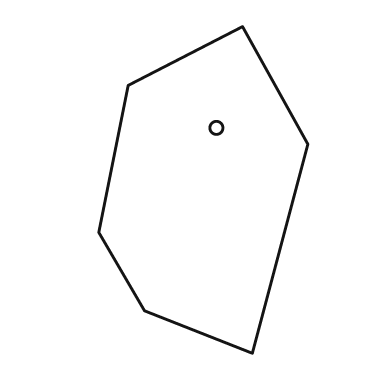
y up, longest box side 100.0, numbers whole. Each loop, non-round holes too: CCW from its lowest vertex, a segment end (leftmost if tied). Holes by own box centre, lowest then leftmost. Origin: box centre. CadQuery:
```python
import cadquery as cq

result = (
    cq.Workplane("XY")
    .moveTo(15.0, -50.0)
    .lineTo(32.0, 14.0)
    .lineTo(12.0, 50.0)
    .lineTo(-23.0, 32.0)
    .lineTo(-32.0, -13.0)
    .lineTo(-18.0, -37.0)
    .close()
    .moveTo(4.0, 19.0)
    .circle(2.0)
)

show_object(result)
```